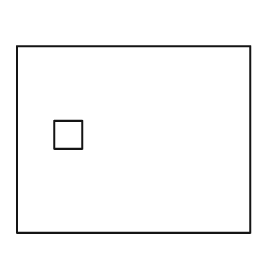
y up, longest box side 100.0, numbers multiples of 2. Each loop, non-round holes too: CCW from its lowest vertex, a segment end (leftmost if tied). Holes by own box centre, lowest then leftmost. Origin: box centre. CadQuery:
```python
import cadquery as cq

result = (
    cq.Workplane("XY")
    .moveTo(-50.0, -40.0)
    .lineTo(50.0, -40.0)
    .lineTo(50.0, 40.0)
    .lineTo(-50.0, 40.0)
    .close()
    .moveTo(-34.0, -4.0)
    .lineTo(-22.0, -4.0)
    .lineTo(-22.0, 8.0)
    .lineTo(-34.0, 8.0)
    .close()
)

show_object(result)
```